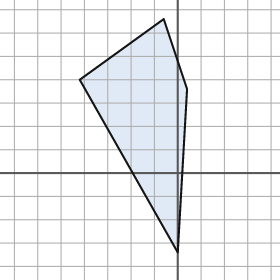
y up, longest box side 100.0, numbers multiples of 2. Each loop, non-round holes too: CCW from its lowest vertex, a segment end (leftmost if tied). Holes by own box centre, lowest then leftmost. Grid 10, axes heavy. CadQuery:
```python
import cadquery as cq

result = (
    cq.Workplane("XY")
    .moveTo(0.0, -34.0)
    .lineTo(4.0, 36.0)
    .lineTo(-6.0, 66.0)
    .lineTo(-42.0, 40.0)
    .close()
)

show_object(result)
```